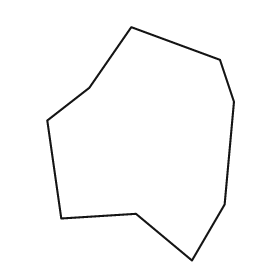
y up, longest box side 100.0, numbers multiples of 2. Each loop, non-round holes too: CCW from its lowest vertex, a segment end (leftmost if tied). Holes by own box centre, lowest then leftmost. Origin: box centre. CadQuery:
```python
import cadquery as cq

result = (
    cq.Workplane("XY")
    .moveTo(22.0, -50.0)
    .lineTo(36.0, -26.0)
    .lineTo(40.0, 18.0)
    .lineTo(34.0, 36.0)
    .lineTo(-4.0, 50.0)
    .lineTo(-22.0, 24.0)
    .lineTo(-40.0, 10.0)
    .lineTo(-34.0, -32.0)
    .lineTo(-2.0, -30.0)
    .close()
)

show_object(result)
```